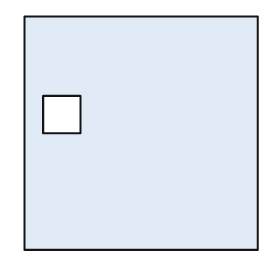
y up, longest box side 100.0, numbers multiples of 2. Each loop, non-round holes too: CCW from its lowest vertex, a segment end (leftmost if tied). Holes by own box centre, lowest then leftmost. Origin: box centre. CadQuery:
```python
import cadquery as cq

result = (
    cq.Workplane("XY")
    .moveTo(-50.0, -50.0)
    .lineTo(50.0, -50.0)
    .lineTo(50.0, 50.0)
    .lineTo(-50.0, 50.0)
    .close()
    .moveTo(-42.0, 0.0)
    .lineTo(-26.0, 0.0)
    .lineTo(-26.0, 16.0)
    .lineTo(-42.0, 16.0)
    .close()
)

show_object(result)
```